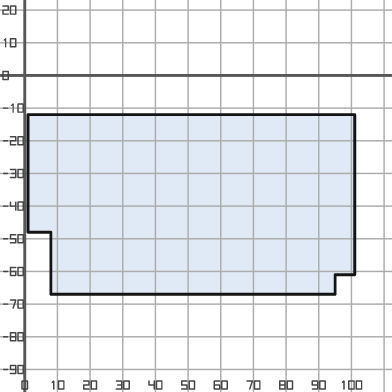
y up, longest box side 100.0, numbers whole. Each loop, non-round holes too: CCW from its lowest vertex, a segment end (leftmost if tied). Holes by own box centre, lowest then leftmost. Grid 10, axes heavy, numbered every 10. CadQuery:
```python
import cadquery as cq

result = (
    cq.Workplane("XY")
    .moveTo(8.0, -67.0)
    .lineTo(95.0, -67.0)
    .lineTo(95.0, -61.0)
    .lineTo(101.0, -61.0)
    .lineTo(101.0, -12.0)
    .lineTo(1.0, -12.0)
    .lineTo(1.0, -48.0)
    .lineTo(8.0, -48.0)
    .close()
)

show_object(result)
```